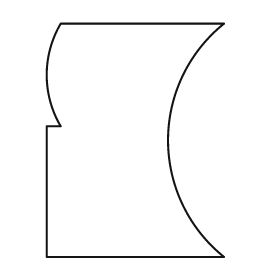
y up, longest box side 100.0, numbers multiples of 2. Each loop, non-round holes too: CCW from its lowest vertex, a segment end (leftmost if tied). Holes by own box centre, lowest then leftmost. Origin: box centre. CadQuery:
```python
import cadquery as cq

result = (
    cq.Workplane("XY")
    .moveTo(-38.0, -50.0)
    .lineTo(38.0, -50.0)
    .threePointArc((14.0, 0.0), (38.0, 50.0))
    .lineTo(-32.0, 50.0)
    .threePointArc((-38.0, 28.0), (-32.0, 6.0))
    .lineTo(-38.0, 6.0)
    .close()
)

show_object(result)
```